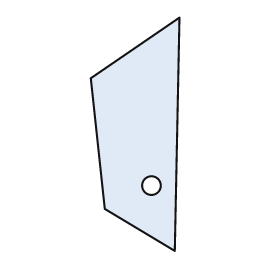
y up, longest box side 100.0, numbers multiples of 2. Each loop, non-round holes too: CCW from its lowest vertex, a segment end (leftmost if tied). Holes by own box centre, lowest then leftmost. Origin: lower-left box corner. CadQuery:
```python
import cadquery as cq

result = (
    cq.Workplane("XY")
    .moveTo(36.0, 0.0)
    .lineTo(38.0, 100.0)
    .lineTo(0.0, 74.0)
    .lineTo(6.0, 18.0)
    .close()
    .moveTo(26.0, 28.0)
    .circle(4.0)
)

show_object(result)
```